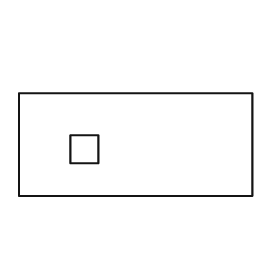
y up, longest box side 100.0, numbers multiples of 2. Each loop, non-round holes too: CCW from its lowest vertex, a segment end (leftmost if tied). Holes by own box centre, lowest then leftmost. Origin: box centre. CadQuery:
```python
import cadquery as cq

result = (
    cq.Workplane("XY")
    .moveTo(-50.0, -22.0)
    .lineTo(50.0, -22.0)
    .lineTo(50.0, 22.0)
    .lineTo(-50.0, 22.0)
    .close()
    .moveTo(-28.0, -8.0)
    .lineTo(-16.0, -8.0)
    .lineTo(-16.0, 4.0)
    .lineTo(-28.0, 4.0)
    .close()
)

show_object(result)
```